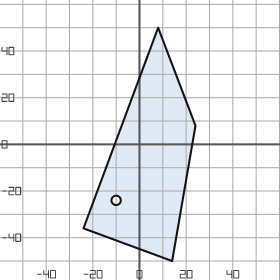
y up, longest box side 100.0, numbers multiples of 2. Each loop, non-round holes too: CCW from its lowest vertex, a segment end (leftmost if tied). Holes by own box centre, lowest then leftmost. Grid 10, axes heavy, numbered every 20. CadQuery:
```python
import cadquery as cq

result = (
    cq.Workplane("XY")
    .moveTo(14.0, -50.0)
    .lineTo(24.0, 8.0)
    .lineTo(8.0, 50.0)
    .lineTo(-24.0, -36.0)
    .close()
    .moveTo(-10.0, -24.0)
    .circle(2.0)
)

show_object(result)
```